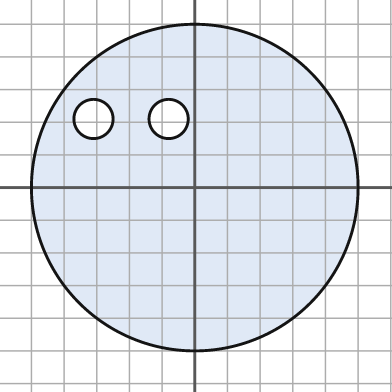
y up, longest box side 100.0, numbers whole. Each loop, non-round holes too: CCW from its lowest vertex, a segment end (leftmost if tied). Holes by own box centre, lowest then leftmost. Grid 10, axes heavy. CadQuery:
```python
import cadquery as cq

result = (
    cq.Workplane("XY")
    .moveTo(0.0, 0.0)
    .circle(50.0)
    .moveTo(-31.0, 21.0)
    .circle(6.0)
    .moveTo(-8.0, 21.0)
    .circle(6.0)
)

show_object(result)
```